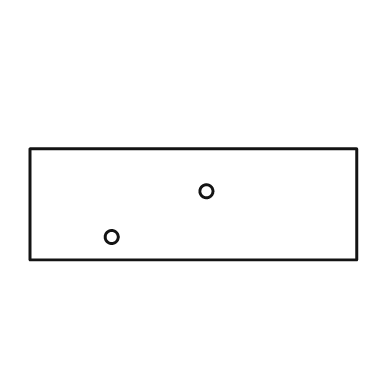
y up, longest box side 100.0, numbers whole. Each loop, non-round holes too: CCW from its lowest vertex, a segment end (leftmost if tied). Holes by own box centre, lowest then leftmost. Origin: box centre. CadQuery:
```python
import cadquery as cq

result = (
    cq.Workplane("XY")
    .moveTo(-50.0, -17.0)
    .lineTo(50.0, -17.0)
    .lineTo(50.0, 17.0)
    .lineTo(-50.0, 17.0)
    .close()
    .moveTo(-25.0, -10.0)
    .circle(2.0)
    .moveTo(4.0, 4.0)
    .circle(2.0)
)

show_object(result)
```